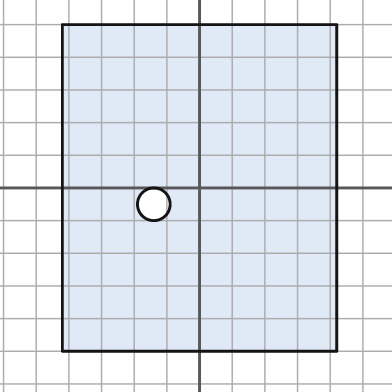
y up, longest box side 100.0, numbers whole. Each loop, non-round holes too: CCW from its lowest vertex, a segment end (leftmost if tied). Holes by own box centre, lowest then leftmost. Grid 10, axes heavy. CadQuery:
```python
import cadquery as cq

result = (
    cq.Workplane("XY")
    .moveTo(-42.0, -50.0)
    .lineTo(42.0, -50.0)
    .lineTo(42.0, 50.0)
    .lineTo(-42.0, 50.0)
    .close()
    .moveTo(-14.0, -5.0)
    .circle(5.0)
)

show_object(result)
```